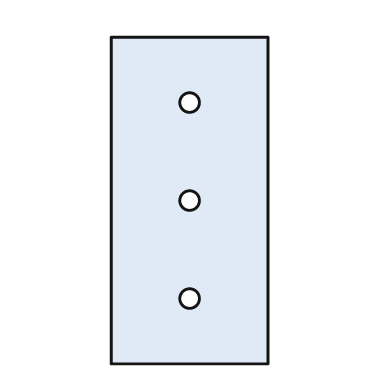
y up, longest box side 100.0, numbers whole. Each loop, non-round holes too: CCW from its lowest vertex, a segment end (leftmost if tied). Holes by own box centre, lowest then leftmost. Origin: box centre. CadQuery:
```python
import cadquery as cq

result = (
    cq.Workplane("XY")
    .moveTo(-24.0, -50.0)
    .lineTo(24.0, -50.0)
    .lineTo(24.0, 50.0)
    .lineTo(-24.0, 50.0)
    .close()
    .moveTo(0.0, -30.0)
    .circle(3.0)
    .moveTo(0.0, 0.0)
    .circle(3.0)
    .moveTo(0.0, 30.0)
    .circle(3.0)
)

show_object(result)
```